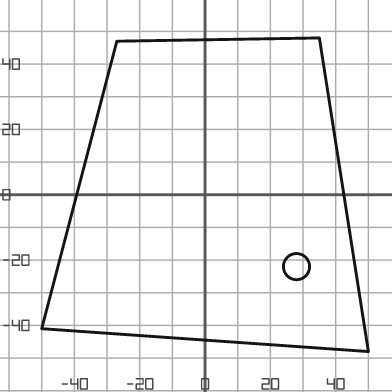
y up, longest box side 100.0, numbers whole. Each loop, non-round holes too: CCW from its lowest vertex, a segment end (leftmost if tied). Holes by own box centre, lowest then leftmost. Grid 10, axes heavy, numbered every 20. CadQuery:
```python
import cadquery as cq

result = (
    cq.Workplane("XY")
    .moveTo(50.0, -48.0)
    .lineTo(35.0, 48.0)
    .lineTo(-27.0, 47.0)
    .lineTo(-50.0, -41.0)
    .close()
    .moveTo(28.0, -22.0)
    .circle(4.0)
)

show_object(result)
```